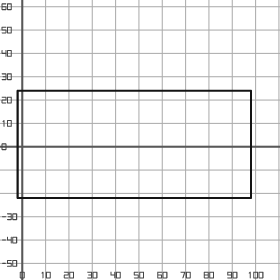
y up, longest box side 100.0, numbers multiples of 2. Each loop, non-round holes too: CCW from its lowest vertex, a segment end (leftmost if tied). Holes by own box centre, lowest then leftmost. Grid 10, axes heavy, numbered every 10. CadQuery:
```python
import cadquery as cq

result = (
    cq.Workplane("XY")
    .moveTo(-2.0, -22.0)
    .lineTo(98.0, -22.0)
    .lineTo(98.0, 24.0)
    .lineTo(-2.0, 24.0)
    .close()
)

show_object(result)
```